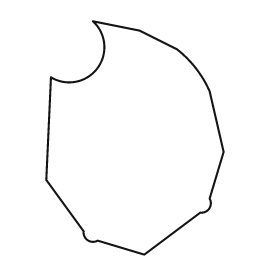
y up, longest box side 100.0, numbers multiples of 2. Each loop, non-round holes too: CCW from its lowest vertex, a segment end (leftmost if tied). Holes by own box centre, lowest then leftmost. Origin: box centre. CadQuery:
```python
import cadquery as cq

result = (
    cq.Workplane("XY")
    .moveTo(4.0, -50.0)
    .lineTo(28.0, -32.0)
    .threePointArc((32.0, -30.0), (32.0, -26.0))
    .lineTo(38.0, -6.0)
    .lineTo(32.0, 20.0)
    .threePointArc((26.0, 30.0), (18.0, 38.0))
    .lineTo(2.0, 46.0)
    .lineTo(-18.0, 50.0)
    .threePointArc((-16.0, 30.0), (-36.0, 26.0))
    .lineTo(-38.0, -18.0)
    .lineTo(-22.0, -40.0)
    .threePointArc((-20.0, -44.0), (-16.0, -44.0))
    .close()
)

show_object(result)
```